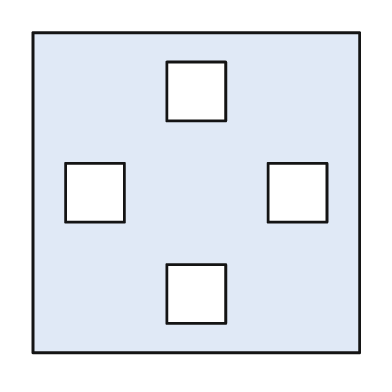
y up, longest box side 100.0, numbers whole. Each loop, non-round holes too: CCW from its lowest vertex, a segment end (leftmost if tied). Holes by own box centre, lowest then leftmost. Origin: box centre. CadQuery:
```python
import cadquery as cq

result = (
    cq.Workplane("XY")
    .moveTo(-50.0, -49.0)
    .lineTo(50.0, -49.0)
    .lineTo(50.0, 49.0)
    .lineTo(-50.0, 49.0)
    .close()
    .moveTo(-9.0, -40.0)
    .lineTo(9.0, -40.0)
    .lineTo(9.0, -22.0)
    .lineTo(-9.0, -22.0)
    .close()
    .moveTo(-40.0, -9.0)
    .lineTo(-22.0, -9.0)
    .lineTo(-22.0, 9.0)
    .lineTo(-40.0, 9.0)
    .close()
    .moveTo(22.0, -9.0)
    .lineTo(40.0, -9.0)
    .lineTo(40.0, 9.0)
    .lineTo(22.0, 9.0)
    .close()
    .moveTo(-9.0, 22.0)
    .lineTo(9.0, 22.0)
    .lineTo(9.0, 40.0)
    .lineTo(-9.0, 40.0)
    .close()
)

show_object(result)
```